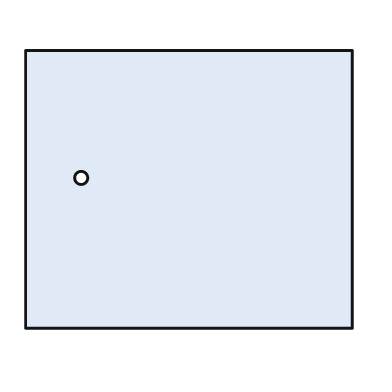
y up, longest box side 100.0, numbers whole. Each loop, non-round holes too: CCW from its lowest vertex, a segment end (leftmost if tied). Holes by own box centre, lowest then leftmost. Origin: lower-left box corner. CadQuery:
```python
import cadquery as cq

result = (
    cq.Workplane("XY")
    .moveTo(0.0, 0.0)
    .lineTo(100.0, 0.0)
    .lineTo(100.0, 85.0)
    .lineTo(0.0, 85.0)
    .close()
    .moveTo(17.0, 46.0)
    .circle(2.0)
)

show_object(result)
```